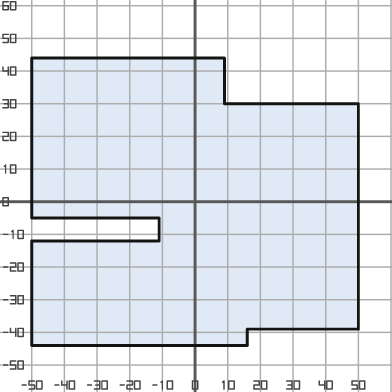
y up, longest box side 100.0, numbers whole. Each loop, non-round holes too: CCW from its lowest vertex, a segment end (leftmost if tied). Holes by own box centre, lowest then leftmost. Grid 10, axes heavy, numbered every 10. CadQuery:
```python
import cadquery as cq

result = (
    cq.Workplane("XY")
    .moveTo(-50.0, -44.0)
    .lineTo(16.0, -44.0)
    .lineTo(16.0, -39.0)
    .lineTo(50.0, -39.0)
    .lineTo(50.0, 30.0)
    .lineTo(9.0, 30.0)
    .lineTo(9.0, 44.0)
    .lineTo(-50.0, 44.0)
    .lineTo(-50.0, -5.0)
    .lineTo(-11.0, -5.0)
    .lineTo(-11.0, -12.0)
    .lineTo(-50.0, -12.0)
    .close()
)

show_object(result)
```